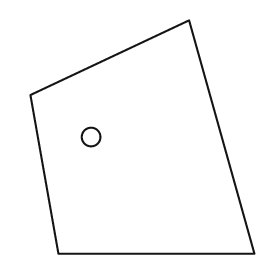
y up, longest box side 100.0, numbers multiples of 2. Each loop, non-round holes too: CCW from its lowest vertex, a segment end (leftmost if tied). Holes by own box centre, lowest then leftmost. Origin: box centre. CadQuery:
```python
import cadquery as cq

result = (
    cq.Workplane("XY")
    .moveTo(-36.0, -50.0)
    .lineTo(48.0, -50.0)
    .lineTo(20.0, 50.0)
    .lineTo(-48.0, 18.0)
    .close()
    .moveTo(-22.0, 0.0)
    .circle(4.0)
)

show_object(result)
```